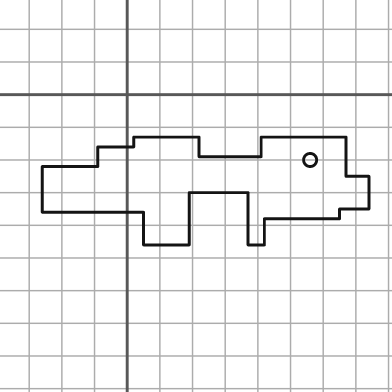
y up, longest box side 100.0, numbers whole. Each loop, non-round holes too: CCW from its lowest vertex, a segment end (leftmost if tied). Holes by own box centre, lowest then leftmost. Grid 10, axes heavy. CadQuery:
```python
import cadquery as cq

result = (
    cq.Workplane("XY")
    .moveTo(5.0, -46.0)
    .lineTo(19.0, -46.0)
    .lineTo(19.0, -30.0)
    .lineTo(37.0, -30.0)
    .lineTo(37.0, -46.0)
    .lineTo(42.0, -46.0)
    .lineTo(42.0, -38.0)
    .lineTo(65.0, -38.0)
    .lineTo(65.0, -35.0)
    .lineTo(74.0, -35.0)
    .lineTo(74.0, -25.0)
    .lineTo(67.0, -25.0)
    .lineTo(67.0, -13.0)
    .lineTo(41.0, -13.0)
    .lineTo(41.0, -19.0)
    .lineTo(22.0, -19.0)
    .lineTo(22.0, -13.0)
    .lineTo(2.0, -13.0)
    .lineTo(2.0, -16.0)
    .lineTo(-9.0, -16.0)
    .lineTo(-9.0, -22.0)
    .lineTo(-26.0, -22.0)
    .lineTo(-26.0, -36.0)
    .lineTo(5.0, -36.0)
    .close()
    .moveTo(56.0, -20.0)
    .circle(2.0)
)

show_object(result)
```